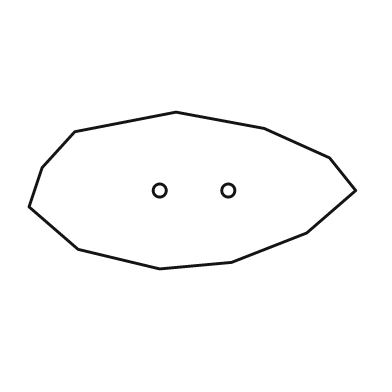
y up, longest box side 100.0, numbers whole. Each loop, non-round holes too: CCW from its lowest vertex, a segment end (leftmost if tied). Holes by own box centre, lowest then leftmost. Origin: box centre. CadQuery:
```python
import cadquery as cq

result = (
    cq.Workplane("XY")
    .moveTo(-10.0, -24.0)
    .lineTo(12.0, -22.0)
    .lineTo(35.0, -13.0)
    .lineTo(50.0, 0.0)
    .lineTo(42.0, 10.0)
    .lineTo(22.0, 19.0)
    .lineTo(-5.0, 24.0)
    .lineTo(-36.0, 18.0)
    .lineTo(-46.0, 7.0)
    .lineTo(-50.0, -5.0)
    .lineTo(-35.0, -18.0)
    .close()
    .moveTo(-10.0, 0.0)
    .circle(2.0)
    .moveTo(11.0, 0.0)
    .circle(2.0)
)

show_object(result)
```